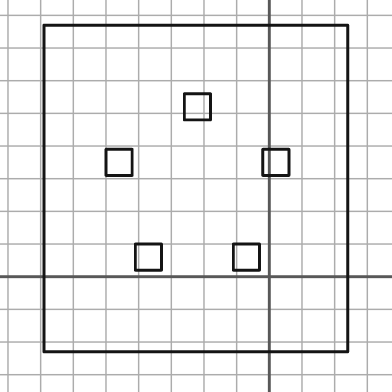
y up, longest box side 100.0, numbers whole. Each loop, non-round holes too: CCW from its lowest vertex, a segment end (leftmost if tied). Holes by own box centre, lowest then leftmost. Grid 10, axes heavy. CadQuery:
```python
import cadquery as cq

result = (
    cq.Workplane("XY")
    .moveTo(-69.0, -23.0)
    .lineTo(24.0, -23.0)
    .lineTo(24.0, 77.0)
    .lineTo(-69.0, 77.0)
    .close()
    .moveTo(-41.0, 2.0)
    .lineTo(-33.0, 2.0)
    .lineTo(-33.0, 10.0)
    .lineTo(-41.0, 10.0)
    .close()
    .moveTo(-11.0, 2.0)
    .lineTo(-3.0, 2.0)
    .lineTo(-3.0, 10.0)
    .lineTo(-11.0, 10.0)
    .close()
    .moveTo(-50.0, 31.0)
    .lineTo(-42.0, 31.0)
    .lineTo(-42.0, 39.0)
    .lineTo(-50.0, 39.0)
    .close()
    .moveTo(-2.0, 31.0)
    .lineTo(6.0, 31.0)
    .lineTo(6.0, 39.0)
    .lineTo(-2.0, 39.0)
    .close()
    .moveTo(-26.0, 48.0)
    .lineTo(-18.0, 48.0)
    .lineTo(-18.0, 56.0)
    .lineTo(-26.0, 56.0)
    .close()
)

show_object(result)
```